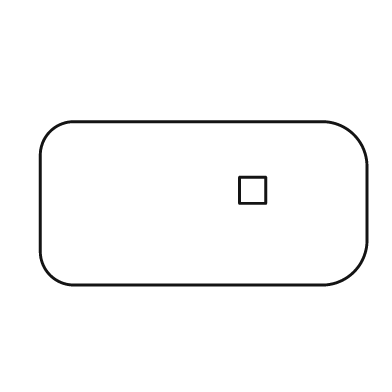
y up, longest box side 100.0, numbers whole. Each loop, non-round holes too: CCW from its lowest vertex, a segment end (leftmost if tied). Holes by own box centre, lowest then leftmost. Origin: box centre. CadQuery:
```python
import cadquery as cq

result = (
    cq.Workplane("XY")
    .moveTo(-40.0, -25.0)
    .lineTo(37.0, -25.0)
    .threePointArc((46.0, -21.0), (50.0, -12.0))
    .lineTo(50.0, 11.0)
    .threePointArc((46.0, 21.0), (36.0, 25.0))
    .lineTo(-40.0, 25.0)
    .threePointArc((-47.0, 22.0), (-50.0, 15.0))
    .lineTo(-50.0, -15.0)
    .threePointArc((-47.0, -22.0), (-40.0, -25.0))
    .close()
    .moveTo(11.0, 0.0)
    .lineTo(19.0, 0.0)
    .lineTo(19.0, 8.0)
    .lineTo(11.0, 8.0)
    .close()
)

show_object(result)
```